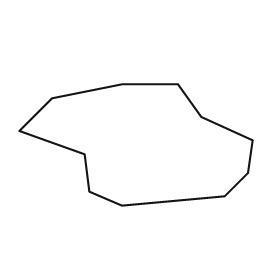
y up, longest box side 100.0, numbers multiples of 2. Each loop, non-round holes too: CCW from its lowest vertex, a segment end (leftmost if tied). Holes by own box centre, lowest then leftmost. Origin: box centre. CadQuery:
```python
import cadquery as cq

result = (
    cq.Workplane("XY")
    .moveTo(-6.0, -26.0)
    .lineTo(38.0, -22.0)
    .lineTo(48.0, -12.0)
    .lineTo(50.0, 2.0)
    .lineTo(28.0, 12.0)
    .lineTo(18.0, 26.0)
    .lineTo(-6.0, 26.0)
    .lineTo(-36.0, 20.0)
    .lineTo(-50.0, 6.0)
    .lineTo(-22.0, -4.0)
    .lineTo(-20.0, -20.0)
    .close()
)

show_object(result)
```